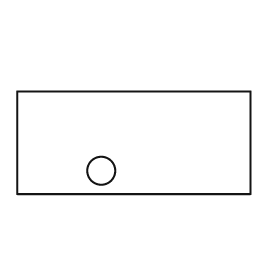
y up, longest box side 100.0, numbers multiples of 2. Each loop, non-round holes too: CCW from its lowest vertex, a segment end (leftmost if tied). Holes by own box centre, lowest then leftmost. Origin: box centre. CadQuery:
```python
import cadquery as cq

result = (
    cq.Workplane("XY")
    .moveTo(-50.0, -22.0)
    .lineTo(50.0, -22.0)
    .lineTo(50.0, 22.0)
    .lineTo(-50.0, 22.0)
    .close()
    .moveTo(-14.0, -12.0)
    .circle(6.0)
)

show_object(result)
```